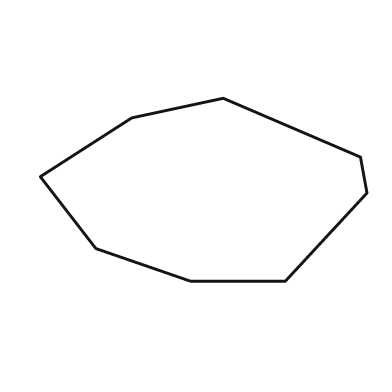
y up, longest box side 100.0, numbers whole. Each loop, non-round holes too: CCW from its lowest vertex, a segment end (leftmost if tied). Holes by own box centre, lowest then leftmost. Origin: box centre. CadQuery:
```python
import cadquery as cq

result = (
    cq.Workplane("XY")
    .moveTo(-4.0, -28.0)
    .lineTo(25.0, -28.0)
    .lineTo(50.0, -1.0)
    .lineTo(48.0, 10.0)
    .lineTo(6.0, 28.0)
    .lineTo(-22.0, 22.0)
    .lineTo(-50.0, 4.0)
    .lineTo(-33.0, -18.0)
    .close()
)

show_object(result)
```